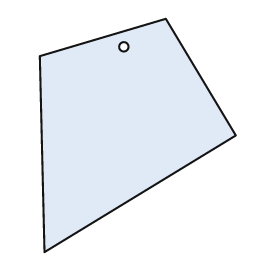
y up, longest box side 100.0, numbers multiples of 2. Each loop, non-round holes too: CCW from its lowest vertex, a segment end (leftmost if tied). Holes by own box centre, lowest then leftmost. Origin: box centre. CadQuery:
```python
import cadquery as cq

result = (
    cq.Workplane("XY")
    .moveTo(-40.0, -50.0)
    .lineTo(42.0, 0.0)
    .lineTo(12.0, 50.0)
    .lineTo(-42.0, 34.0)
    .close()
    .moveTo(-6.0, 38.0)
    .circle(2.0)
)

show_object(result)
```